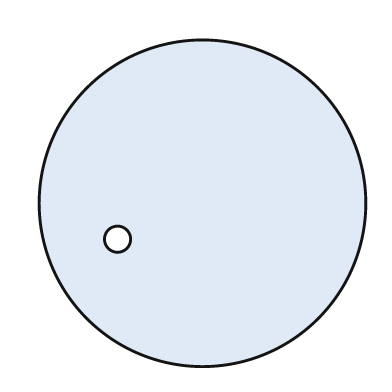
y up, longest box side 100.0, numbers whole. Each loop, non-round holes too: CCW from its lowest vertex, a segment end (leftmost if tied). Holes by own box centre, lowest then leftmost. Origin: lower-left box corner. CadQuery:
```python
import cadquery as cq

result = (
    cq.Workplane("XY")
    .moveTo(50.0, 50.0)
    .circle(50.0)
    .moveTo(24.0, 39.0)
    .circle(4.0)
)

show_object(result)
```